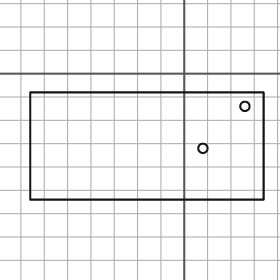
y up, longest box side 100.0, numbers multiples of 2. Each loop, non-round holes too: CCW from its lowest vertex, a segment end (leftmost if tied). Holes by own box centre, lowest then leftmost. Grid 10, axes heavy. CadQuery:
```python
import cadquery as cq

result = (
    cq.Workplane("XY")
    .moveTo(-66.0, -54.0)
    .lineTo(34.0, -54.0)
    .lineTo(34.0, -8.0)
    .lineTo(-66.0, -8.0)
    .close()
    .moveTo(8.0, -32.0)
    .circle(2.0)
    .moveTo(26.0, -14.0)
    .circle(2.0)
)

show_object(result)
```